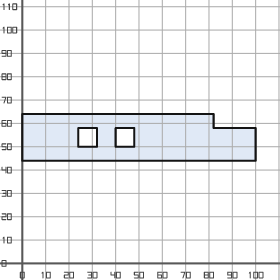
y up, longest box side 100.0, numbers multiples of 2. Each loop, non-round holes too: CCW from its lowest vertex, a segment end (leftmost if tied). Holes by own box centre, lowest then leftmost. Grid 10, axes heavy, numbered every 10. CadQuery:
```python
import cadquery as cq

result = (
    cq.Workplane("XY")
    .moveTo(0.0, 44.0)
    .lineTo(100.0, 44.0)
    .lineTo(100.0, 58.0)
    .lineTo(82.0, 58.0)
    .lineTo(82.0, 64.0)
    .lineTo(0.0, 64.0)
    .close()
    .moveTo(24.0, 50.0)
    .lineTo(32.0, 50.0)
    .lineTo(32.0, 58.0)
    .lineTo(24.0, 58.0)
    .close()
    .moveTo(40.0, 50.0)
    .lineTo(48.0, 50.0)
    .lineTo(48.0, 58.0)
    .lineTo(40.0, 58.0)
    .close()
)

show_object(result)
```